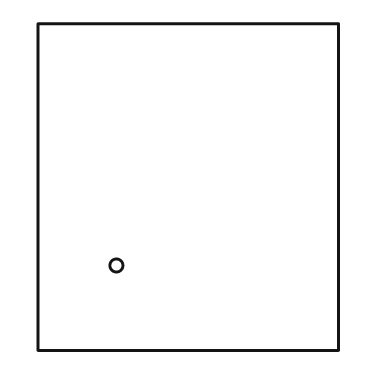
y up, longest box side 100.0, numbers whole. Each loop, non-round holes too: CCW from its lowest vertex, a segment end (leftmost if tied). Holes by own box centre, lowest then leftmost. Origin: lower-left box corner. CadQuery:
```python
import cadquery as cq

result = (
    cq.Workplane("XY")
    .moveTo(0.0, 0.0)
    .lineTo(92.0, 0.0)
    .lineTo(92.0, 100.0)
    .lineTo(0.0, 100.0)
    .close()
    .moveTo(24.0, 26.0)
    .circle(2.0)
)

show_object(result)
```